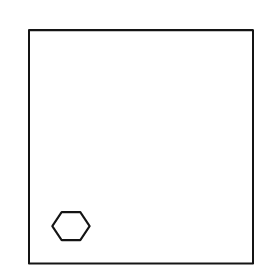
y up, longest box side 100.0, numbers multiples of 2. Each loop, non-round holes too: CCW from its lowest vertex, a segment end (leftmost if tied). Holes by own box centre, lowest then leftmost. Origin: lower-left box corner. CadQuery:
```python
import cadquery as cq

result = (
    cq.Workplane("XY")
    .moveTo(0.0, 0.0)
    .lineTo(96.0, 0.0)
    .lineTo(96.0, 100.0)
    .lineTo(0.0, 100.0)
    .close()
    .moveTo(14.0, 10.0)
    .lineTo(22.0, 10.0)
    .lineTo(26.0, 16.0)
    .lineTo(22.0, 22.0)
    .lineTo(14.0, 22.0)
    .lineTo(10.0, 16.0)
    .close()
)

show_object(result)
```